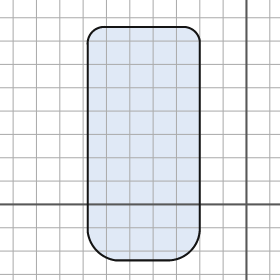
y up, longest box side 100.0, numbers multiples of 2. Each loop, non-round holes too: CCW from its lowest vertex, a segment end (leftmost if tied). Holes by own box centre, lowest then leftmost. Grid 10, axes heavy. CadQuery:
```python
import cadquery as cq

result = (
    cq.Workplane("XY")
    .moveTo(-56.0, -24.0)
    .lineTo(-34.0, -24.0)
    .threePointArc((-24.0, -20.0), (-20.0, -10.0))
    .lineTo(-20.0, 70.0)
    .threePointArc((-22.0, 74.0), (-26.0, 76.0))
    .lineTo(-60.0, 76.0)
    .threePointArc((-66.0, 74.0), (-68.0, 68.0))
    .lineTo(-68.0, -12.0)
    .threePointArc((-64.0, -20.0), (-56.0, -24.0))
    .close()
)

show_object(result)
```